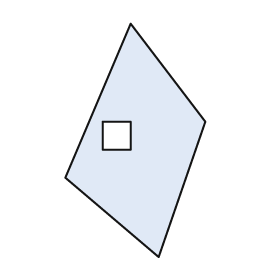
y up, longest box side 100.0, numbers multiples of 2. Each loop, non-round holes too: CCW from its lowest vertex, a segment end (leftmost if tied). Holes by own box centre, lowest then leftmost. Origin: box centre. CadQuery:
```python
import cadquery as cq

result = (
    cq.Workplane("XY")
    .moveTo(10.0, -50.0)
    .lineTo(30.0, 8.0)
    .lineTo(-2.0, 50.0)
    .lineTo(-30.0, -16.0)
    .close()
    .moveTo(-14.0, -4.0)
    .lineTo(-2.0, -4.0)
    .lineTo(-2.0, 8.0)
    .lineTo(-14.0, 8.0)
    .close()
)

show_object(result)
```